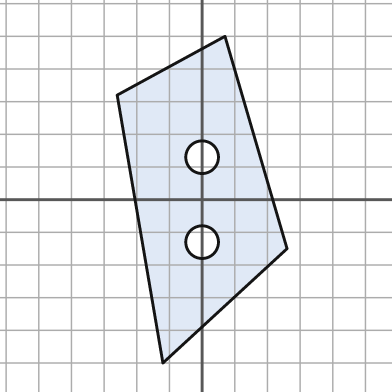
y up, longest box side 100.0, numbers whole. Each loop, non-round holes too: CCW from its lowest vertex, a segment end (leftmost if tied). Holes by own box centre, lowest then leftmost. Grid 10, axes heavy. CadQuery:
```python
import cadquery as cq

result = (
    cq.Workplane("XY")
    .moveTo(-12.0, -50.0)
    .lineTo(26.0, -15.0)
    .lineTo(7.0, 50.0)
    .lineTo(-26.0, 32.0)
    .close()
    .moveTo(0.0, -13.0)
    .circle(5.0)
    .moveTo(0.0, 13.0)
    .circle(5.0)
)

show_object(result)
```